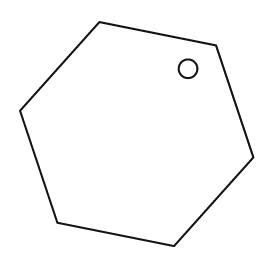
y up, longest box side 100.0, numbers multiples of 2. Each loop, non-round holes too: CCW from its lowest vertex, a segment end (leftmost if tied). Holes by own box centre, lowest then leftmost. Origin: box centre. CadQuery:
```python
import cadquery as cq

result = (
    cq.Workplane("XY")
    .moveTo(16.0, -48.0)
    .lineTo(50.0, -10.0)
    .lineTo(34.0, 38.0)
    .lineTo(-16.0, 48.0)
    .lineTo(-50.0, 10.0)
    .lineTo(-34.0, -38.0)
    .close()
    .moveTo(22.0, 28.0)
    .circle(4.0)
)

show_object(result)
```